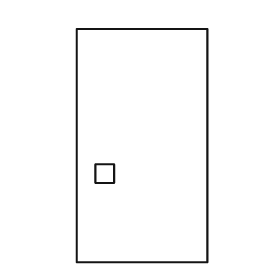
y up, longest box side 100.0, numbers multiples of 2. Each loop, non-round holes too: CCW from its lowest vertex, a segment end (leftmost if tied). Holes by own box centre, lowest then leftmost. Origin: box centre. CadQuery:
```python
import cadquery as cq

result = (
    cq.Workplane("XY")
    .moveTo(-28.0, -50.0)
    .lineTo(28.0, -50.0)
    .lineTo(28.0, 50.0)
    .lineTo(-28.0, 50.0)
    .close()
    .moveTo(-20.0, -16.0)
    .lineTo(-12.0, -16.0)
    .lineTo(-12.0, -8.0)
    .lineTo(-20.0, -8.0)
    .close()
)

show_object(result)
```